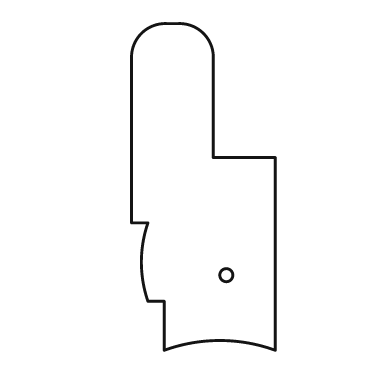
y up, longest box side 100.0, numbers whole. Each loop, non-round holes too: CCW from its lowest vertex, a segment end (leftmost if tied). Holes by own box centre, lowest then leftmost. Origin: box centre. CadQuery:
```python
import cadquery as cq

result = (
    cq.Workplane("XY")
    .moveTo(-12.0, -50.0)
    .threePointArc((5.0, -47.0), (22.0, -50.0))
    .lineTo(22.0, 9.0)
    .lineTo(3.0, 9.0)
    .lineTo(3.0, 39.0)
    .threePointArc((0.0, 47.0), (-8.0, 50.0))
    .lineTo(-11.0, 50.0)
    .threePointArc((-19.0, 47.0), (-22.0, 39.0))
    .lineTo(-22.0, -11.0)
    .lineTo(-17.0, -11.0)
    .threePointArc((-19.0, -23.0), (-17.0, -35.0))
    .lineTo(-12.0, -35.0)
    .close()
    .moveTo(7.0, -27.0)
    .circle(2.0)
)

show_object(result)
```